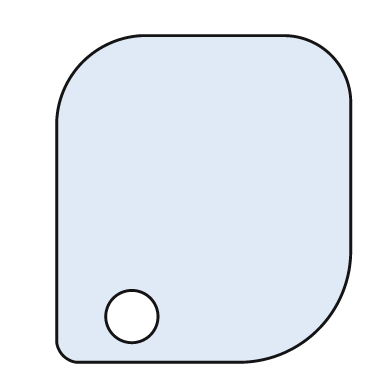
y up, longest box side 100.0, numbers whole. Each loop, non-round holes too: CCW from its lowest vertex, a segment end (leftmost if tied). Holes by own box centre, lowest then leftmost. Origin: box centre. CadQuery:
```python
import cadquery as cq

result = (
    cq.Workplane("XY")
    .moveTo(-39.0, -50.0)
    .lineTo(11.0, -50.0)
    .threePointArc((35.0, -40.0), (45.0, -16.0))
    .lineTo(45.0, 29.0)
    .threePointArc((39.0, 44.0), (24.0, 50.0))
    .lineTo(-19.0, 50.0)
    .threePointArc((-37.0, 42.0), (-45.0, 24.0))
    .lineTo(-45.0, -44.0)
    .threePointArc((-43.0, -48.0), (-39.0, -50.0))
    .close()
    .moveTo(-22.0, -36.0)
    .circle(8.0)
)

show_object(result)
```